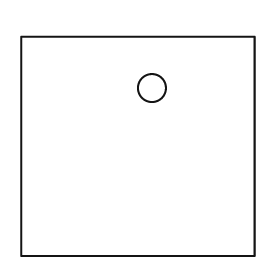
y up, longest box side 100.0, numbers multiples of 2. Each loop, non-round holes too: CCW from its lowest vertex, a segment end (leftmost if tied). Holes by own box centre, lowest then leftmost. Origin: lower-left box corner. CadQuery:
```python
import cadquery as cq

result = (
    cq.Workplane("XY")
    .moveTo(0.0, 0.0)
    .lineTo(100.0, 0.0)
    .lineTo(100.0, 94.0)
    .lineTo(0.0, 94.0)
    .close()
    .moveTo(56.0, 72.0)
    .circle(6.0)
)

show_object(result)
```